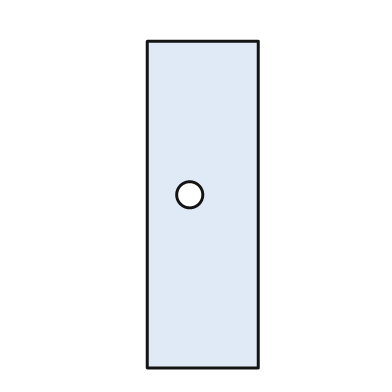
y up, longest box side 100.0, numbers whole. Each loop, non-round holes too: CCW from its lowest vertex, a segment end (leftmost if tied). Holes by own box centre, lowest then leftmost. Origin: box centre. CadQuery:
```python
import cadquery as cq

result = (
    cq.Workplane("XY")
    .moveTo(-17.0, -50.0)
    .lineTo(17.0, -50.0)
    .lineTo(17.0, 50.0)
    .lineTo(-17.0, 50.0)
    .close()
    .moveTo(-4.0, 3.0)
    .circle(4.0)
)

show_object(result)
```